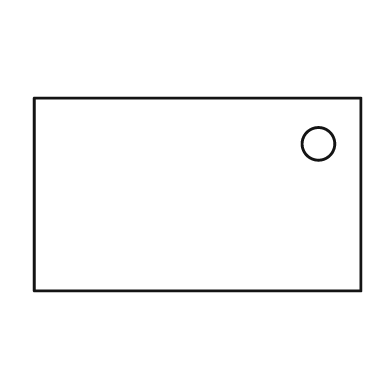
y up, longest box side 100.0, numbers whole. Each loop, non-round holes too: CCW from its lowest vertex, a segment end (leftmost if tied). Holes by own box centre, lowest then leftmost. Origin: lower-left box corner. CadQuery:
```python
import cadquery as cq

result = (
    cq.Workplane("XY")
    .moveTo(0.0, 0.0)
    .lineTo(100.0, 0.0)
    .lineTo(100.0, 59.0)
    .lineTo(0.0, 59.0)
    .close()
    .moveTo(87.0, 45.0)
    .circle(5.0)
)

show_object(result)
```